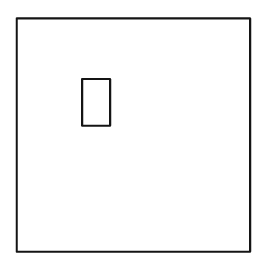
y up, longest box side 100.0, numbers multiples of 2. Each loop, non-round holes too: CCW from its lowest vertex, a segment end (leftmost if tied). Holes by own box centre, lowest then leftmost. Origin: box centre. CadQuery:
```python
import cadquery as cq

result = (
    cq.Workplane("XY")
    .moveTo(-50.0, -50.0)
    .lineTo(50.0, -50.0)
    .lineTo(50.0, 50.0)
    .lineTo(-50.0, 50.0)
    .close()
    .moveTo(-22.0, 4.0)
    .lineTo(-10.0, 4.0)
    .lineTo(-10.0, 24.0)
    .lineTo(-22.0, 24.0)
    .close()
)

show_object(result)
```